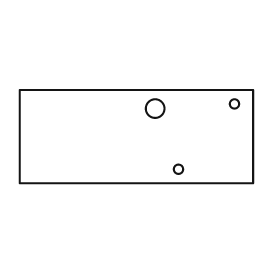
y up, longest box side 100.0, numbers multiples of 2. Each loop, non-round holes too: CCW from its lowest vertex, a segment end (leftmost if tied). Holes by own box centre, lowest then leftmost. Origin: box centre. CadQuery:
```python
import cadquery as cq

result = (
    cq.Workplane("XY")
    .moveTo(-50.0, -20.0)
    .lineTo(50.0, -20.0)
    .lineTo(50.0, 20.0)
    .lineTo(-50.0, 20.0)
    .close()
    .moveTo(18.0, -14.0)
    .circle(2.0)
    .moveTo(8.0, 12.0)
    .circle(4.0)
    .moveTo(42.0, 14.0)
    .circle(2.0)
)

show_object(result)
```